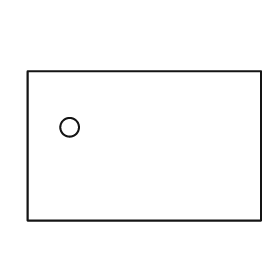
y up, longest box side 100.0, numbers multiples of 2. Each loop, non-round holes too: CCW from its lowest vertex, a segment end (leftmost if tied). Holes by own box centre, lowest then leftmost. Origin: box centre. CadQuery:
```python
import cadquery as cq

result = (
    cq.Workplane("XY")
    .moveTo(-50.0, -32.0)
    .lineTo(50.0, -32.0)
    .lineTo(50.0, 32.0)
    .lineTo(-50.0, 32.0)
    .close()
    .moveTo(-32.0, 8.0)
    .circle(4.0)
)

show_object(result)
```